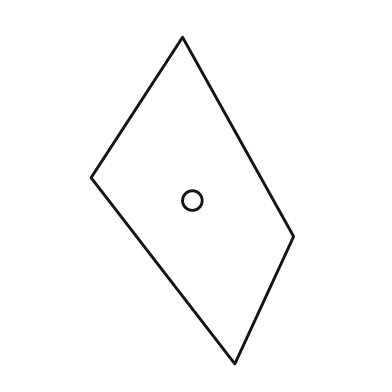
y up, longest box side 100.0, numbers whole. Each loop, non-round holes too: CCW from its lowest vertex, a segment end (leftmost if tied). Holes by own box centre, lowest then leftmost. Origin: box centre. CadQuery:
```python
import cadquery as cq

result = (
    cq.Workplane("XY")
    .moveTo(13.0, -50.0)
    .lineTo(31.0, -11.0)
    .lineTo(-3.0, 50.0)
    .lineTo(-31.0, 7.0)
    .close()
    .moveTo(0.0, 0.0)
    .circle(3.0)
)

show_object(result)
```